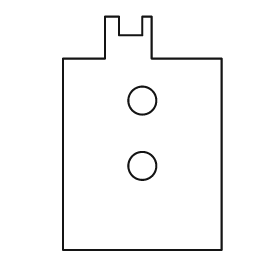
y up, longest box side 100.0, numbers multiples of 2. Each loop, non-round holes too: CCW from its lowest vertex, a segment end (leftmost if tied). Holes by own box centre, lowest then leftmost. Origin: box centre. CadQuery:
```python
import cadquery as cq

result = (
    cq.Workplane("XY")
    .moveTo(-34.0, -50.0)
    .lineTo(34.0, -50.0)
    .lineTo(34.0, 32.0)
    .lineTo(4.0, 32.0)
    .lineTo(4.0, 50.0)
    .lineTo(0.0, 50.0)
    .lineTo(0.0, 42.0)
    .lineTo(-10.0, 42.0)
    .lineTo(-10.0, 50.0)
    .lineTo(-16.0, 50.0)
    .lineTo(-16.0, 32.0)
    .lineTo(-34.0, 32.0)
    .close()
    .moveTo(0.0, -14.0)
    .circle(6.0)
    .moveTo(0.0, 14.0)
    .circle(6.0)
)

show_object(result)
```